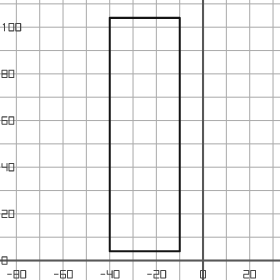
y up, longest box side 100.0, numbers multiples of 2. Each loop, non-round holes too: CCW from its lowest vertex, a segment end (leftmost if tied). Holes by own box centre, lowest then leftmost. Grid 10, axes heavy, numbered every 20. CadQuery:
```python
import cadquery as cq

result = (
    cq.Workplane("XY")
    .moveTo(-40.0, 4.0)
    .lineTo(-10.0, 4.0)
    .lineTo(-10.0, 104.0)
    .lineTo(-40.0, 104.0)
    .close()
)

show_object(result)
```